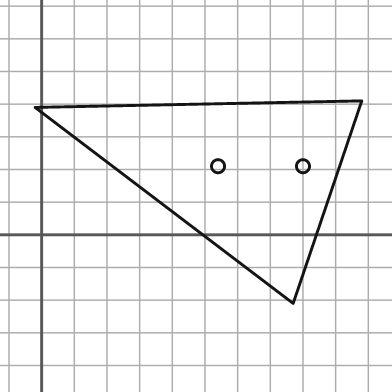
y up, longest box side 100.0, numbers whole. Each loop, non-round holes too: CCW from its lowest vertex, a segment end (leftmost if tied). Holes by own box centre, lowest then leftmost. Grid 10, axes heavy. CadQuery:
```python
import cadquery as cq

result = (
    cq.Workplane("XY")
    .moveTo(77.0, -21.0)
    .lineTo(98.0, 41.0)
    .lineTo(-2.0, 39.0)
    .close()
    .moveTo(54.0, 21.0)
    .circle(2.0)
    .moveTo(80.0, 21.0)
    .circle(2.0)
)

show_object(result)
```